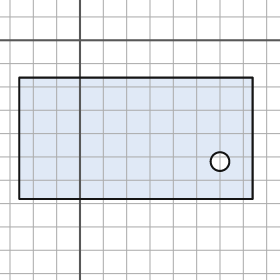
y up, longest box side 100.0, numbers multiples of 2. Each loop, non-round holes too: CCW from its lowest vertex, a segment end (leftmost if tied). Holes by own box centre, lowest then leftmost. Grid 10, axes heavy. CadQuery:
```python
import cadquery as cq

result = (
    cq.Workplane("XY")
    .moveTo(-26.0, -68.0)
    .lineTo(74.0, -68.0)
    .lineTo(74.0, -16.0)
    .lineTo(-26.0, -16.0)
    .close()
    .moveTo(60.0, -52.0)
    .circle(4.0)
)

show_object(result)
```